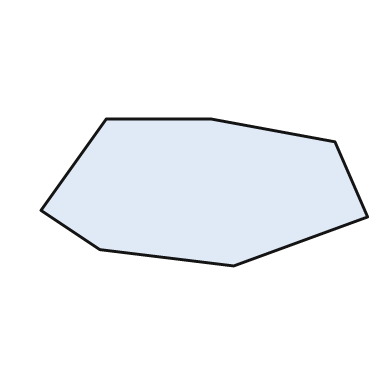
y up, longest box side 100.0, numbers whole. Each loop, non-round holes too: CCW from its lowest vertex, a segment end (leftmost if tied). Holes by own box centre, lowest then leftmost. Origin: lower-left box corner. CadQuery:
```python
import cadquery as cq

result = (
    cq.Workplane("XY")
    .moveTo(59.0, 0.0)
    .lineTo(100.0, 15.0)
    .lineTo(90.0, 38.0)
    .lineTo(52.0, 45.0)
    .lineTo(20.0, 45.0)
    .lineTo(0.0, 17.0)
    .lineTo(18.0, 5.0)
    .close()
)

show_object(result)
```